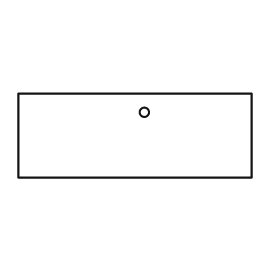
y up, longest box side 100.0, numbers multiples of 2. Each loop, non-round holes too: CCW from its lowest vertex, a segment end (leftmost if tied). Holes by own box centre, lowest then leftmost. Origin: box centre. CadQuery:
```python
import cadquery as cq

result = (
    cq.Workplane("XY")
    .moveTo(-50.0, -18.0)
    .lineTo(50.0, -18.0)
    .lineTo(50.0, 18.0)
    .lineTo(-50.0, 18.0)
    .close()
    .moveTo(4.0, 10.0)
    .circle(2.0)
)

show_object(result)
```